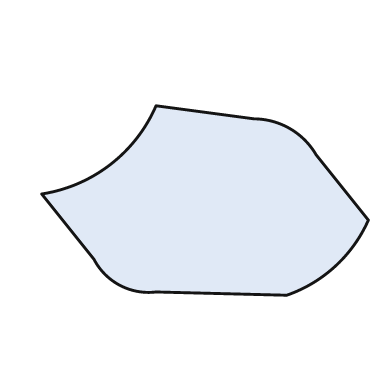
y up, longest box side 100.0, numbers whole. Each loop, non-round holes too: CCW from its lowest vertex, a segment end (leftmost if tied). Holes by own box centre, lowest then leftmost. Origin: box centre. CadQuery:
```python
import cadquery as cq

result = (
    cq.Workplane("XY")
    .moveTo(25.0, -29.0)
    .threePointArc((40.0, -20.0), (50.0, -6.0))
    .lineTo(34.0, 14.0)
    .threePointArc((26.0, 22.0), (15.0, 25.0))
    .lineTo(-15.0, 29.0)
    .threePointArc((-29.0, 11.0), (-50.0, 2.0))
    .lineTo(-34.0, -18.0)
    .threePointArc((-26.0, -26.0), (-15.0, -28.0))
    .close()
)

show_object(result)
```